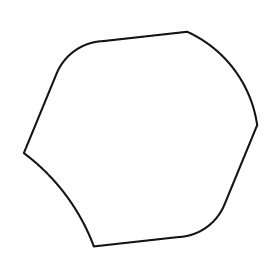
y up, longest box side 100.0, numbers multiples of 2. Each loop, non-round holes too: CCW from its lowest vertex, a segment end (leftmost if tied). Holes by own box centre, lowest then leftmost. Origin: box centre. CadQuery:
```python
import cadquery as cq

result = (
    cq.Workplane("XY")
    .moveTo(-20.0, -46.0)
    .lineTo(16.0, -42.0)
    .threePointArc((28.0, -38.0), (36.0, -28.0))
    .lineTo(50.0, 6.0)
    .threePointArc((40.0, 30.0), (20.0, 46.0))
    .lineTo(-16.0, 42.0)
    .threePointArc((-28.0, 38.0), (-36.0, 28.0))
    .lineTo(-50.0, -6.0)
    .threePointArc((-32.0, -24.0), (-20.0, -46.0))
    .close()
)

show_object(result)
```